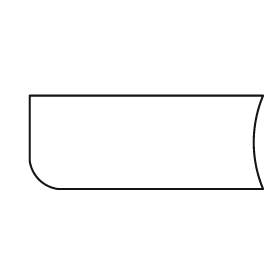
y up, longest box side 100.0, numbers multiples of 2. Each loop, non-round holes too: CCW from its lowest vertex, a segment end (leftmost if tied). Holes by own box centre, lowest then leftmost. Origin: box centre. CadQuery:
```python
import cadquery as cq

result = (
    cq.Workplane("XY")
    .moveTo(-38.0, -20.0)
    .lineTo(50.0, -20.0)
    .threePointArc((46.0, 0.0), (50.0, 20.0))
    .lineTo(-50.0, 20.0)
    .lineTo(-50.0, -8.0)
    .threePointArc((-46.0, -16.0), (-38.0, -20.0))
    .close()
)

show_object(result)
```